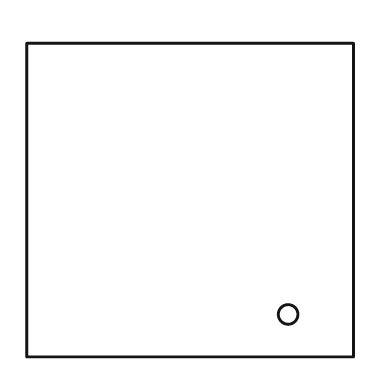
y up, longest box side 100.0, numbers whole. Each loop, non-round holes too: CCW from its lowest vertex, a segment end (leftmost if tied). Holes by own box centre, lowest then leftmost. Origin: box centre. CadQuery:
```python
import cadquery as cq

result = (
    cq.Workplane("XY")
    .moveTo(-50.0, -48.0)
    .lineTo(50.0, -48.0)
    .lineTo(50.0, 48.0)
    .lineTo(-50.0, 48.0)
    .close()
    .moveTo(30.0, -35.0)
    .circle(3.0)
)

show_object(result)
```